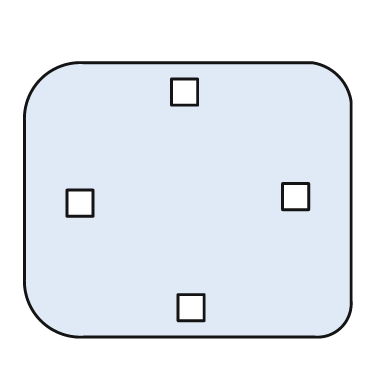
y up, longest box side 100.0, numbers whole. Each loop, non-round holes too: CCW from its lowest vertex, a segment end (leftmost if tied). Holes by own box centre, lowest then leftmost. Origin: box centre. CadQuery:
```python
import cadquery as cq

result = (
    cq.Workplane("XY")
    .moveTo(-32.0, -42.0)
    .lineTo(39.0, -42.0)
    .threePointArc((47.0, -39.0), (50.0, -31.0))
    .lineTo(50.0, 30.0)
    .threePointArc((46.0, 38.0), (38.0, 42.0))
    .lineTo(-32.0, 42.0)
    .threePointArc((-45.0, 37.0), (-50.0, 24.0))
    .lineTo(-50.0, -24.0)
    .threePointArc((-45.0, -37.0), (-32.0, -42.0))
    .close()
    .moveTo(-3.0, -37.0)
    .lineTo(5.0, -37.0)
    .lineTo(5.0, -29.0)
    .lineTo(-3.0, -29.0)
    .close()
    .moveTo(-37.0, -5.0)
    .lineTo(-29.0, -5.0)
    .lineTo(-29.0, 3.0)
    .lineTo(-37.0, 3.0)
    .close()
    .moveTo(29.0, -3.0)
    .lineTo(37.0, -3.0)
    .lineTo(37.0, 5.0)
    .lineTo(29.0, 5.0)
    .close()
    .moveTo(-5.0, 29.0)
    .lineTo(3.0, 29.0)
    .lineTo(3.0, 37.0)
    .lineTo(-5.0, 37.0)
    .close()
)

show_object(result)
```